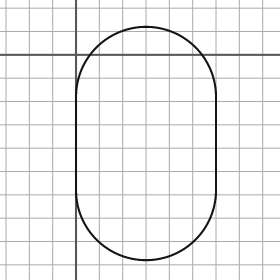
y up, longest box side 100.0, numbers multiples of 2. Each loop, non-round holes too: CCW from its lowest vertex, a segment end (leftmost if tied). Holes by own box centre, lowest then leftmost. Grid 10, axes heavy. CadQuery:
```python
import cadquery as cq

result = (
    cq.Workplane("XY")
    .moveTo(0.0, -58.0)
    .threePointArc((30.0, -88.0), (60.0, -58.0))
    .lineTo(60.0, -18.0)
    .threePointArc((30.0, 12.0), (0.0, -18.0))
    .close()
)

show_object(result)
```